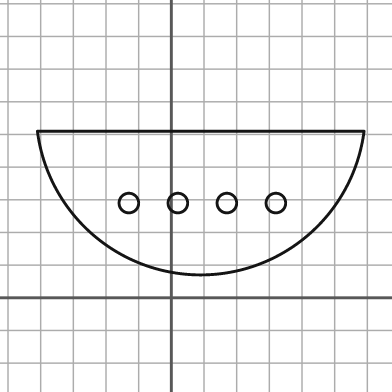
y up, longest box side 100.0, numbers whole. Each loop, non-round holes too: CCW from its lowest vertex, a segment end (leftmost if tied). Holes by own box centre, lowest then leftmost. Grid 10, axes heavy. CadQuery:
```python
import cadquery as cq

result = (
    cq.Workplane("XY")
    .moveTo(-41.0, 51.0)
    .threePointArc((9.0, 7.0), (59.0, 51.0))
    .close()
    .moveTo(-13.0, 29.0)
    .circle(3.0)
    .moveTo(2.0, 29.0)
    .circle(3.0)
    .moveTo(17.0, 29.0)
    .circle(3.0)
    .moveTo(32.0, 29.0)
    .circle(3.0)
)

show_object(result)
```